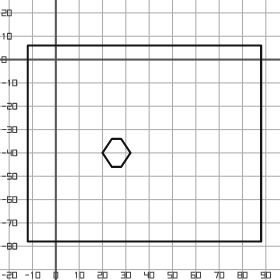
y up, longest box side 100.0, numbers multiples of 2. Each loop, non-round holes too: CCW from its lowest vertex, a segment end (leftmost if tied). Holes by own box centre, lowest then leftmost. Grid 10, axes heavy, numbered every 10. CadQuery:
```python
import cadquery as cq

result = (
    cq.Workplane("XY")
    .moveTo(-12.0, -78.0)
    .lineTo(88.0, -78.0)
    .lineTo(88.0, 6.0)
    .lineTo(-12.0, 6.0)
    .close()
    .moveTo(24.0, -46.0)
    .lineTo(28.0, -46.0)
    .lineTo(32.0, -40.0)
    .lineTo(28.0, -34.0)
    .lineTo(24.0, -34.0)
    .lineTo(20.0, -40.0)
    .close()
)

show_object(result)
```